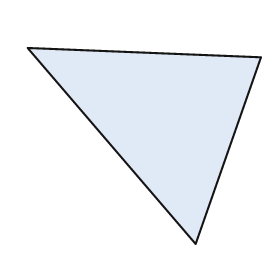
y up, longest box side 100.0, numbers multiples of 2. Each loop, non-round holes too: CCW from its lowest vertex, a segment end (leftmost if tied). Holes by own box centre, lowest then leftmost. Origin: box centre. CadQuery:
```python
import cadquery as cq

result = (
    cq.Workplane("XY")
    .moveTo(22.0, -42.0)
    .lineTo(50.0, 38.0)
    .lineTo(-50.0, 42.0)
    .close()
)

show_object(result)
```